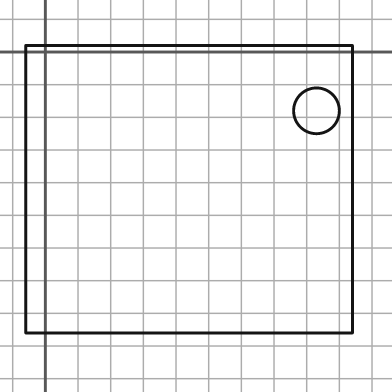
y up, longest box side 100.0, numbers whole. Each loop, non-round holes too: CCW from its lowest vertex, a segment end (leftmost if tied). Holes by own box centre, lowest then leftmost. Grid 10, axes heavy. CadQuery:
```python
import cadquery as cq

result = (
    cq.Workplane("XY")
    .moveTo(-6.0, -86.0)
    .lineTo(94.0, -86.0)
    .lineTo(94.0, 2.0)
    .lineTo(-6.0, 2.0)
    .close()
    .moveTo(83.0, -18.0)
    .circle(7.0)
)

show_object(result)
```